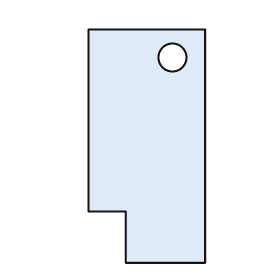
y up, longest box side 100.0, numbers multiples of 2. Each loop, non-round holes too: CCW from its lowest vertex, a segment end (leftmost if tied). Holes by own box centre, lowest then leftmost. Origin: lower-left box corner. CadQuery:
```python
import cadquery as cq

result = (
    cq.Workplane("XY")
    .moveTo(16.0, 0.0)
    .lineTo(50.0, 0.0)
    .lineTo(50.0, 100.0)
    .lineTo(0.0, 100.0)
    .lineTo(0.0, 22.0)
    .lineTo(16.0, 22.0)
    .close()
    .moveTo(36.0, 88.0)
    .circle(6.0)
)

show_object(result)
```